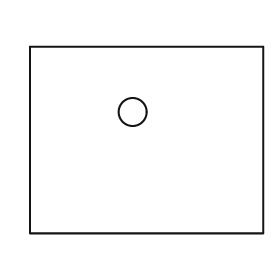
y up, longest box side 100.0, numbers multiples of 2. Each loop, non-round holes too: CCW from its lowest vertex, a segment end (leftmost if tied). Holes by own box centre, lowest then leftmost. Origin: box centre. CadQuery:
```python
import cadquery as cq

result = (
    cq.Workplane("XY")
    .moveTo(-50.0, -40.0)
    .lineTo(50.0, -40.0)
    .lineTo(50.0, 40.0)
    .lineTo(-50.0, 40.0)
    .close()
    .moveTo(-6.0, 12.0)
    .circle(6.0)
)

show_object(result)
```